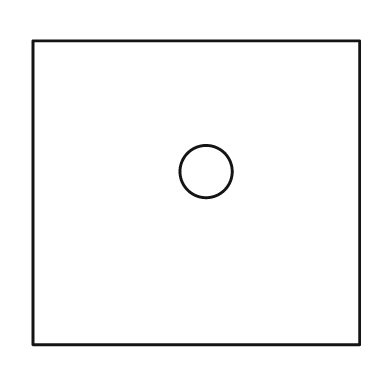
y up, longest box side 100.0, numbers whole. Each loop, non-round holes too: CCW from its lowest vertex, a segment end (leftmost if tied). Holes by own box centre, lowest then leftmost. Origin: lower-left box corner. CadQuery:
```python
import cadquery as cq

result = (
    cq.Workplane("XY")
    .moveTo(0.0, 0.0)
    .lineTo(100.0, 0.0)
    .lineTo(100.0, 93.0)
    .lineTo(0.0, 93.0)
    .close()
    .moveTo(53.0, 53.0)
    .circle(8.0)
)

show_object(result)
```